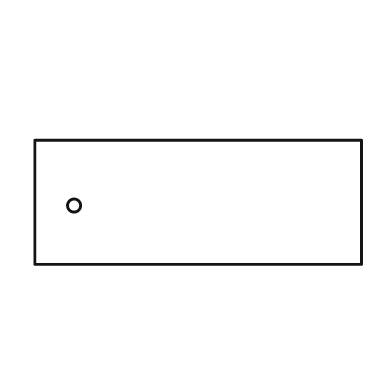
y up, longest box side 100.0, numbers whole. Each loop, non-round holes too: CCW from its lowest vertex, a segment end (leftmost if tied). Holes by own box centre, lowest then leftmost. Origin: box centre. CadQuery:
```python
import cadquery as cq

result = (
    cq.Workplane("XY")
    .moveTo(-50.0, -19.0)
    .lineTo(50.0, -19.0)
    .lineTo(50.0, 19.0)
    .lineTo(-50.0, 19.0)
    .close()
    .moveTo(-38.0, -1.0)
    .circle(2.0)
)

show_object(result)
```